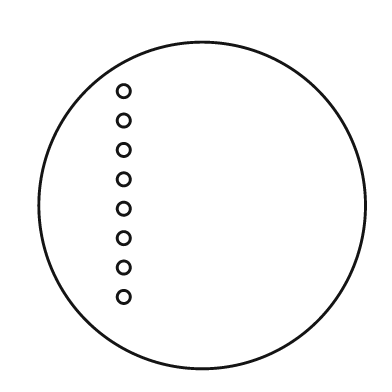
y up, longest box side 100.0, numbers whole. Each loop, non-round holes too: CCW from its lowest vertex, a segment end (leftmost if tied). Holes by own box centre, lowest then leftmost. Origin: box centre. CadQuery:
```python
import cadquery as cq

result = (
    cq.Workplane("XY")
    .moveTo(0.0, 0.0)
    .circle(50.0)
    .moveTo(-24.0, -28.0)
    .circle(2.0)
    .moveTo(-24.0, -19.0)
    .circle(2.0)
    .moveTo(-24.0, -10.0)
    .circle(2.0)
    .moveTo(-24.0, -1.0)
    .circle(2.0)
    .moveTo(-24.0, 8.0)
    .circle(2.0)
    .moveTo(-24.0, 17.0)
    .circle(2.0)
    .moveTo(-24.0, 26.0)
    .circle(2.0)
    .moveTo(-24.0, 35.0)
    .circle(2.0)
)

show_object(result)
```